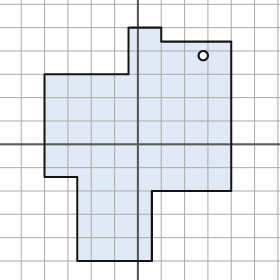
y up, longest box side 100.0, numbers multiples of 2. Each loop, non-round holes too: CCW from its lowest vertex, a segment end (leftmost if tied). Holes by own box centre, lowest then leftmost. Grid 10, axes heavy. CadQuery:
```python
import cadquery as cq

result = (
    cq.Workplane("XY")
    .moveTo(-26.0, -50.0)
    .lineTo(6.0, -50.0)
    .lineTo(6.0, -20.0)
    .lineTo(40.0, -20.0)
    .lineTo(40.0, 44.0)
    .lineTo(10.0, 44.0)
    .lineTo(10.0, 50.0)
    .lineTo(-4.0, 50.0)
    .lineTo(-4.0, 30.0)
    .lineTo(-40.0, 30.0)
    .lineTo(-40.0, -14.0)
    .lineTo(-26.0, -14.0)
    .close()
    .moveTo(28.0, 38.0)
    .circle(2.0)
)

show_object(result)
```